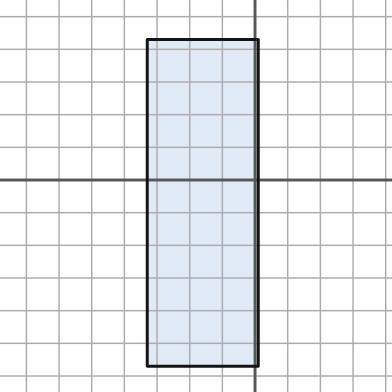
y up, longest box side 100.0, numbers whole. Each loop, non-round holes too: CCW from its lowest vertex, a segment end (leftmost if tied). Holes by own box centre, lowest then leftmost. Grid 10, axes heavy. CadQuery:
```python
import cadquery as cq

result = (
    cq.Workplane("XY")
    .moveTo(-33.0, -57.0)
    .lineTo(1.0, -57.0)
    .lineTo(1.0, 43.0)
    .lineTo(-33.0, 43.0)
    .close()
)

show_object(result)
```